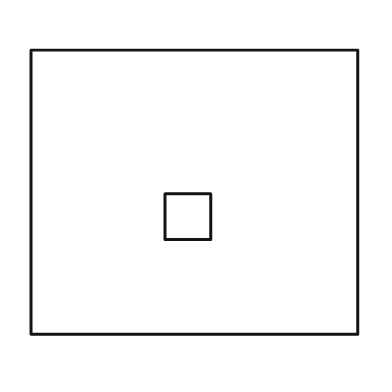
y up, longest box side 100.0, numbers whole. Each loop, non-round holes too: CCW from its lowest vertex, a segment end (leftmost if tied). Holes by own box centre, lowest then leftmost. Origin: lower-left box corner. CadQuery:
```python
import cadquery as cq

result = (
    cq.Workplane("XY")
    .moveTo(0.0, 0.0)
    .lineTo(100.0, 0.0)
    .lineTo(100.0, 87.0)
    .lineTo(0.0, 87.0)
    .close()
    .moveTo(41.0, 29.0)
    .lineTo(55.0, 29.0)
    .lineTo(55.0, 43.0)
    .lineTo(41.0, 43.0)
    .close()
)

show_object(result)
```